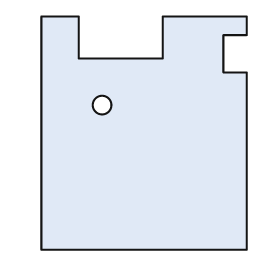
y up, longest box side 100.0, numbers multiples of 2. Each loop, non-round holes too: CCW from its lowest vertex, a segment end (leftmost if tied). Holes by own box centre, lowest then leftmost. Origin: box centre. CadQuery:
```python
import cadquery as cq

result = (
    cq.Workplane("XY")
    .moveTo(-44.0, -50.0)
    .lineTo(44.0, -50.0)
    .lineTo(44.0, 26.0)
    .lineTo(34.0, 26.0)
    .lineTo(34.0, 42.0)
    .lineTo(44.0, 42.0)
    .lineTo(44.0, 50.0)
    .lineTo(8.0, 50.0)
    .lineTo(8.0, 32.0)
    .lineTo(-28.0, 32.0)
    .lineTo(-28.0, 50.0)
    .lineTo(-44.0, 50.0)
    .close()
    .moveTo(-18.0, 12.0)
    .circle(4.0)
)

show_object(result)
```